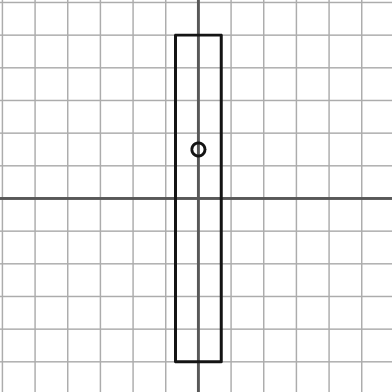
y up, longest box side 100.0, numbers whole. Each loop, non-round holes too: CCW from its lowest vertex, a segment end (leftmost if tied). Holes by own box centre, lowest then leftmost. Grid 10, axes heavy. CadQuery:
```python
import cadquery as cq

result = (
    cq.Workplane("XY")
    .moveTo(-7.0, -50.0)
    .lineTo(7.0, -50.0)
    .lineTo(7.0, 50.0)
    .lineTo(-7.0, 50.0)
    .close()
    .moveTo(0.0, 15.0)
    .circle(2.0)
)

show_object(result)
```